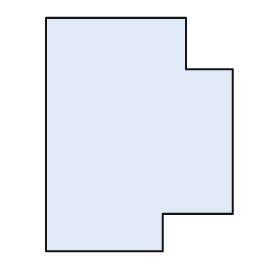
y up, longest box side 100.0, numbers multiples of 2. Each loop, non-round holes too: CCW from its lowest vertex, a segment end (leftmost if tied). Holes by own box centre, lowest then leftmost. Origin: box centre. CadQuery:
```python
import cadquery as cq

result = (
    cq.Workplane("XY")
    .moveTo(-40.0, -50.0)
    .lineTo(10.0, -50.0)
    .lineTo(10.0, -34.0)
    .lineTo(40.0, -34.0)
    .lineTo(40.0, 28.0)
    .lineTo(20.0, 28.0)
    .lineTo(20.0, 50.0)
    .lineTo(-40.0, 50.0)
    .close()
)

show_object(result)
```